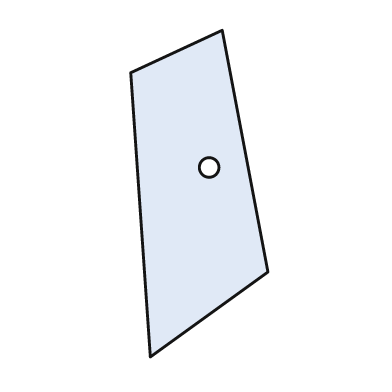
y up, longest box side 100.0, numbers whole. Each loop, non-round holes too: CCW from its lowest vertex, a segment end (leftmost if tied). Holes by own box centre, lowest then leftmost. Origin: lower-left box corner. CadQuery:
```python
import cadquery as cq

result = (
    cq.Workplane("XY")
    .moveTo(6.0, 0.0)
    .lineTo(42.0, 26.0)
    .lineTo(28.0, 100.0)
    .lineTo(0.0, 87.0)
    .close()
    .moveTo(24.0, 58.0)
    .circle(3.0)
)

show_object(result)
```